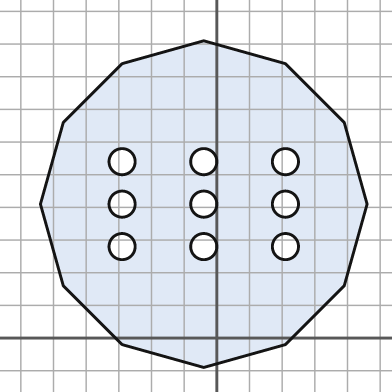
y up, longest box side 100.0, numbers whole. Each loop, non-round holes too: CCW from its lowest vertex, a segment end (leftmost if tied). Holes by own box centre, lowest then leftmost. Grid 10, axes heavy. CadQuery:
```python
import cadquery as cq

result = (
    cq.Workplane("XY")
    .moveTo(-4.0, -9.0)
    .lineTo(21.0, -2.0)
    .lineTo(39.0, 16.0)
    .lineTo(46.0, 41.0)
    .lineTo(39.0, 66.0)
    .lineTo(21.0, 84.0)
    .lineTo(-4.0, 91.0)
    .lineTo(-29.0, 84.0)
    .lineTo(-47.0, 66.0)
    .lineTo(-54.0, 41.0)
    .lineTo(-47.0, 16.0)
    .lineTo(-29.0, -2.0)
    .close()
    .moveTo(-29.0, 28.0)
    .circle(4.0)
    .moveTo(-4.0, 28.0)
    .circle(4.0)
    .moveTo(21.0, 28.0)
    .circle(4.0)
    .moveTo(-29.0, 41.0)
    .circle(4.0)
    .moveTo(-4.0, 41.0)
    .circle(4.0)
    .moveTo(21.0, 41.0)
    .circle(4.0)
    .moveTo(-29.0, 54.0)
    .circle(4.0)
    .moveTo(-4.0, 54.0)
    .circle(4.0)
    .moveTo(21.0, 54.0)
    .circle(4.0)
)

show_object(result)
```